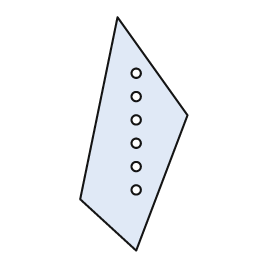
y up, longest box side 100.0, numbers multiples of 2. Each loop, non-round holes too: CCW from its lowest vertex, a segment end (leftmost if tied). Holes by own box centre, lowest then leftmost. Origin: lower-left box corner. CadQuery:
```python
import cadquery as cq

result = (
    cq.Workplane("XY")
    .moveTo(24.0, 0.0)
    .lineTo(46.0, 58.0)
    .lineTo(16.0, 100.0)
    .lineTo(0.0, 22.0)
    .close()
    .moveTo(24.0, 26.0)
    .circle(2.0)
    .moveTo(24.0, 36.0)
    .circle(2.0)
    .moveTo(24.0, 46.0)
    .circle(2.0)
    .moveTo(24.0, 56.0)
    .circle(2.0)
    .moveTo(24.0, 66.0)
    .circle(2.0)
    .moveTo(24.0, 76.0)
    .circle(2.0)
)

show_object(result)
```